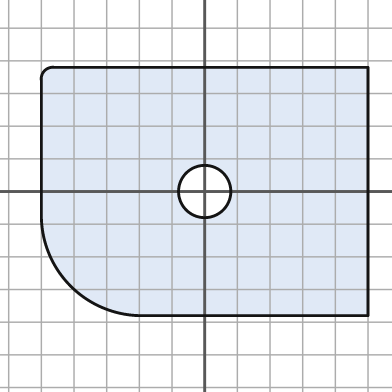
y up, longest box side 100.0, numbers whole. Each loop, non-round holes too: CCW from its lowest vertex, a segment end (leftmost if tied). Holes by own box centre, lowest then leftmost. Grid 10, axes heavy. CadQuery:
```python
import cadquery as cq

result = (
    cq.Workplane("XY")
    .moveTo(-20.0, -38.0)
    .lineTo(50.0, -38.0)
    .lineTo(50.0, 38.0)
    .lineTo(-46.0, 38.0)
    .threePointArc((-49.0, 37.0), (-50.0, 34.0))
    .lineTo(-50.0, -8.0)
    .threePointArc((-41.0, -29.0), (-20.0, -38.0))
    .close()
    .moveTo(0.0, 0.0)
    .circle(8.0)
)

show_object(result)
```